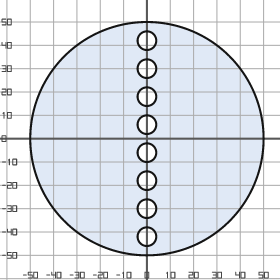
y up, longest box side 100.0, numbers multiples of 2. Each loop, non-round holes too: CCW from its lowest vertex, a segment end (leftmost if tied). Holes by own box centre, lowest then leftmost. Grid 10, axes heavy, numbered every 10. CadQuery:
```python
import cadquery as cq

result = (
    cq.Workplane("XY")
    .moveTo(0.0, 0.0)
    .circle(50.0)
    .moveTo(0.0, -42.0)
    .circle(4.0)
    .moveTo(0.0, -30.0)
    .circle(4.0)
    .moveTo(0.0, -18.0)
    .circle(4.0)
    .moveTo(0.0, -6.0)
    .circle(4.0)
    .moveTo(0.0, 6.0)
    .circle(4.0)
    .moveTo(0.0, 18.0)
    .circle(4.0)
    .moveTo(0.0, 30.0)
    .circle(4.0)
    .moveTo(0.0, 42.0)
    .circle(4.0)
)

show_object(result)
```